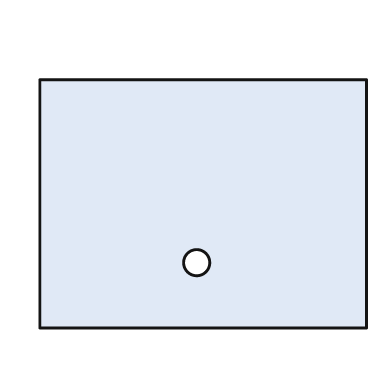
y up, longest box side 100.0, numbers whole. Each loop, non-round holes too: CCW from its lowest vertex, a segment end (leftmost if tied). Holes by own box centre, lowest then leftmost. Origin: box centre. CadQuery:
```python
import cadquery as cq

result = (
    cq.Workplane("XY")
    .moveTo(-50.0, -38.0)
    .lineTo(50.0, -38.0)
    .lineTo(50.0, 38.0)
    .lineTo(-50.0, 38.0)
    .close()
    .moveTo(-2.0, -18.0)
    .circle(4.0)
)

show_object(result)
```